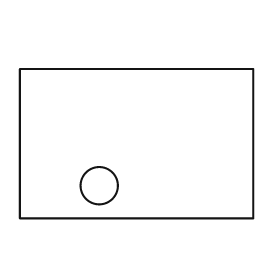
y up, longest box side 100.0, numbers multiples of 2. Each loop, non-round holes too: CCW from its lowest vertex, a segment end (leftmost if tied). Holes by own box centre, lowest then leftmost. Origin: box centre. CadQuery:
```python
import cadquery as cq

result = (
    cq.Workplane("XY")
    .moveTo(-50.0, -32.0)
    .lineTo(50.0, -32.0)
    .lineTo(50.0, 32.0)
    .lineTo(-50.0, 32.0)
    .close()
    .moveTo(-16.0, -18.0)
    .circle(8.0)
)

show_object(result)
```